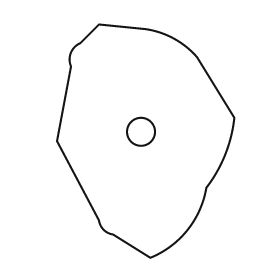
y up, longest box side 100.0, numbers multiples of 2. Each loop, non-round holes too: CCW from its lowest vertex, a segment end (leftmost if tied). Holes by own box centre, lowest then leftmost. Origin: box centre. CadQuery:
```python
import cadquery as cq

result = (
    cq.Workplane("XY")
    .moveTo(2.0, -50.0)
    .threePointArc((18.0, -38.0), (26.0, -20.0))
    .threePointArc((34.0, -6.0), (38.0, 10.0))
    .lineTo(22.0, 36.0)
    .threePointArc((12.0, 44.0), (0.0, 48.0))
    .lineTo(-20.0, 50.0)
    .lineTo(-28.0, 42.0)
    .threePointArc((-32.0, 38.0), (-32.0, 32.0))
    .lineTo(-38.0, 0.0)
    .lineTo(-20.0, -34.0)
    .threePointArc((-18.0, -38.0), (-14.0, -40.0))
    .close()
    .moveTo(-2.0, 4.0)
    .circle(6.0)
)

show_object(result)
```